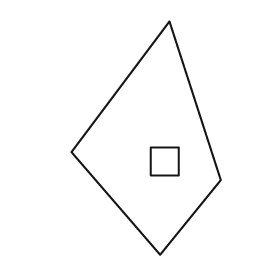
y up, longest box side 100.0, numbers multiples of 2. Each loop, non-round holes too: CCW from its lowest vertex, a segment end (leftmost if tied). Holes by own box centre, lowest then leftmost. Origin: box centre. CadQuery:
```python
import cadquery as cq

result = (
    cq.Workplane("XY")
    .moveTo(6.0, -50.0)
    .lineTo(32.0, -18.0)
    .lineTo(10.0, 50.0)
    .lineTo(-32.0, -6.0)
    .close()
    .moveTo(2.0, -16.0)
    .lineTo(14.0, -16.0)
    .lineTo(14.0, -4.0)
    .lineTo(2.0, -4.0)
    .close()
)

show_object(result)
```